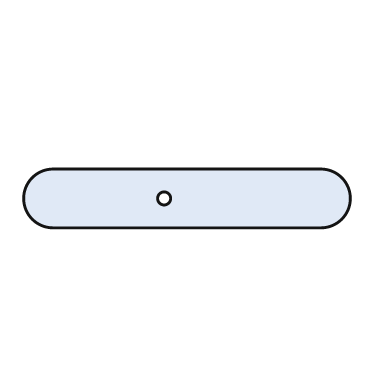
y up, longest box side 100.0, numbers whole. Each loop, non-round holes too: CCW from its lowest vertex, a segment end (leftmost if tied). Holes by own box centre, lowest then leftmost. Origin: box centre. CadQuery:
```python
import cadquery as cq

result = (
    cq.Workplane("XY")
    .moveTo(-41.0, -9.0)
    .lineTo(41.0, -9.0)
    .threePointArc((50.0, 0.0), (41.0, 9.0))
    .lineTo(-41.0, 9.0)
    .threePointArc((-50.0, 0.0), (-41.0, -9.0))
    .close()
    .moveTo(-7.0, 0.0)
    .circle(2.0)
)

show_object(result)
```